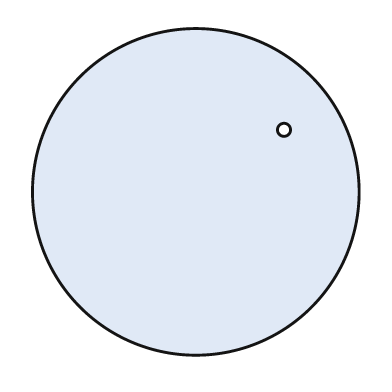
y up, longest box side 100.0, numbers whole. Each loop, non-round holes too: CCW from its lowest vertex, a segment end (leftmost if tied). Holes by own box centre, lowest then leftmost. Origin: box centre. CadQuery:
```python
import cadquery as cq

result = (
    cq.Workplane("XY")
    .moveTo(0.0, 0.0)
    .circle(50.0)
    .moveTo(27.0, 19.0)
    .circle(2.0)
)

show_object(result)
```